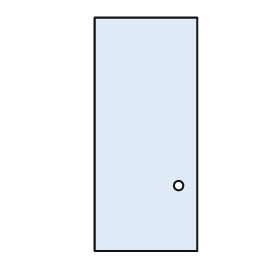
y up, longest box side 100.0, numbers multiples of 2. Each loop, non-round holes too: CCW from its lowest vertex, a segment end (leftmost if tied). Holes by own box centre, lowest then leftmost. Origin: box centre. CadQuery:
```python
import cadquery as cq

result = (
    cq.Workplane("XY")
    .moveTo(-22.0, -50.0)
    .lineTo(22.0, -50.0)
    .lineTo(22.0, 50.0)
    .lineTo(-22.0, 50.0)
    .close()
    .moveTo(14.0, -22.0)
    .circle(2.0)
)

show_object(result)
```